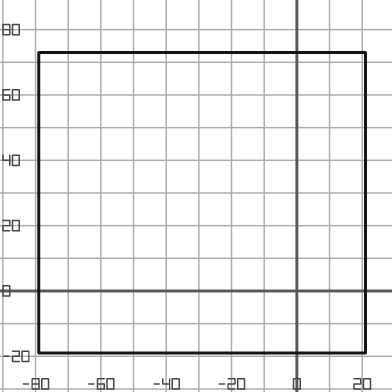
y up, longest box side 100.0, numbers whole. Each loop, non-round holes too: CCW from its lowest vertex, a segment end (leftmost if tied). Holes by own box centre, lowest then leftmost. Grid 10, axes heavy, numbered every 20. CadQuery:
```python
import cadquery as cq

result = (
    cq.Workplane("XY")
    .moveTo(-79.0, -19.0)
    .lineTo(21.0, -19.0)
    .lineTo(21.0, 73.0)
    .lineTo(-79.0, 73.0)
    .close()
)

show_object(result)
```